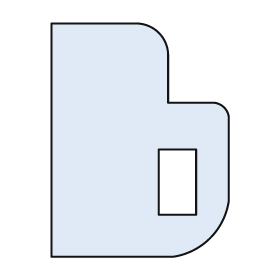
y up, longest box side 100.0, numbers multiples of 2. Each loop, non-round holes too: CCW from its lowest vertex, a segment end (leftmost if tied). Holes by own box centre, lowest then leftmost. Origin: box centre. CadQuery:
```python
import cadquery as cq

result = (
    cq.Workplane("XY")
    .moveTo(-38.0, -50.0)
    .lineTo(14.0, -50.0)
    .threePointArc((30.0, -42.0), (38.0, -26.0))
    .lineTo(38.0, 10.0)
    .threePointArc((36.0, 14.0), (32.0, 16.0))
    .lineTo(12.0, 16.0)
    .lineTo(12.0, 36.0)
    .threePointArc((8.0, 46.0), (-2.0, 50.0))
    .lineTo(-38.0, 50.0)
    .close()
    .moveTo(8.0, -32.0)
    .lineTo(24.0, -32.0)
    .lineTo(24.0, -4.0)
    .lineTo(8.0, -4.0)
    .close()
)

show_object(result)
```